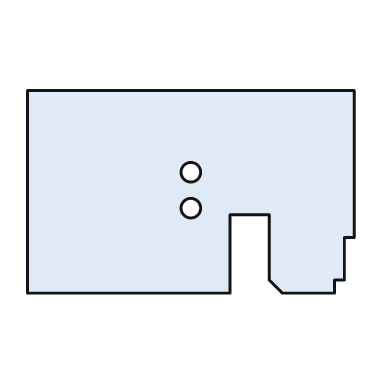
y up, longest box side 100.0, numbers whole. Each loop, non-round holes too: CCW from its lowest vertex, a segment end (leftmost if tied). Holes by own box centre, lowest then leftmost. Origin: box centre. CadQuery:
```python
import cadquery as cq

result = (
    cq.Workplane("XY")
    .moveTo(-50.0, -31.0)
    .lineTo(12.0, -31.0)
    .lineTo(12.0, -7.0)
    .lineTo(24.0, -7.0)
    .lineTo(24.0, -27.0)
    .lineTo(28.0, -31.0)
    .lineTo(44.0, -31.0)
    .lineTo(44.0, -27.0)
    .lineTo(47.0, -27.0)
    .lineTo(47.0, -14.0)
    .lineTo(50.0, -14.0)
    .lineTo(50.0, 31.0)
    .lineTo(-50.0, 31.0)
    .close()
    .moveTo(0.0, -5.0)
    .circle(3.0)
    .moveTo(0.0, 6.0)
    .circle(3.0)
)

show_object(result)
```